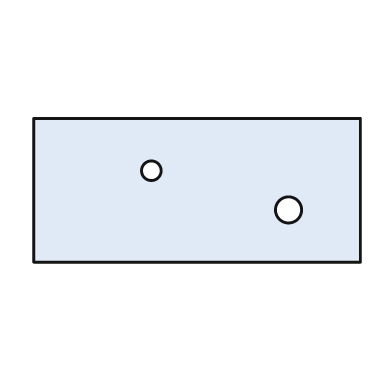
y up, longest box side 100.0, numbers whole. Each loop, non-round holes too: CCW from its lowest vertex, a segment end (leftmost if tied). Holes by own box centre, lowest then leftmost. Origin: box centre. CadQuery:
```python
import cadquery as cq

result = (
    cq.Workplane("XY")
    .moveTo(-50.0, -22.0)
    .lineTo(50.0, -22.0)
    .lineTo(50.0, 22.0)
    .lineTo(-50.0, 22.0)
    .close()
    .moveTo(28.0, -6.0)
    .circle(4.0)
    .moveTo(-14.0, 6.0)
    .circle(3.0)
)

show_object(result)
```